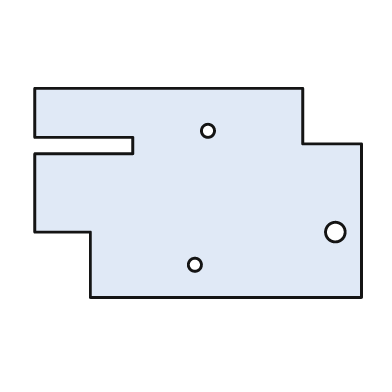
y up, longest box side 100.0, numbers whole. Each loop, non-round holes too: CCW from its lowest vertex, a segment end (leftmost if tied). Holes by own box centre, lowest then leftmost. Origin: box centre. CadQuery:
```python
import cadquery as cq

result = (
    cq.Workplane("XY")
    .moveTo(-33.0, -32.0)
    .lineTo(50.0, -32.0)
    .lineTo(50.0, 15.0)
    .lineTo(32.0, 15.0)
    .lineTo(32.0, 32.0)
    .lineTo(-50.0, 32.0)
    .lineTo(-50.0, 17.0)
    .lineTo(-20.0, 17.0)
    .lineTo(-20.0, 12.0)
    .lineTo(-50.0, 12.0)
    .lineTo(-50.0, -12.0)
    .lineTo(-33.0, -12.0)
    .close()
    .moveTo(-1.0, -22.0)
    .circle(2.0)
    .moveTo(42.0, -12.0)
    .circle(3.0)
    .moveTo(3.0, 19.0)
    .circle(2.0)
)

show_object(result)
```